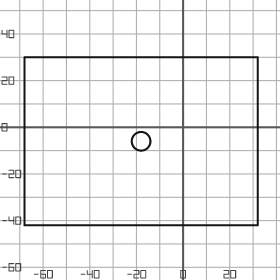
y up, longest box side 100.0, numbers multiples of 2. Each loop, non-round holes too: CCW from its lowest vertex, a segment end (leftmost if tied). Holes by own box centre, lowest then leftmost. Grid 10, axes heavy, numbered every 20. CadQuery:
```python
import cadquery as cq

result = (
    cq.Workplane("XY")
    .moveTo(-68.0, -42.0)
    .lineTo(32.0, -42.0)
    .lineTo(32.0, 30.0)
    .lineTo(-68.0, 30.0)
    .close()
    .moveTo(-18.0, -6.0)
    .circle(4.0)
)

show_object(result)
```